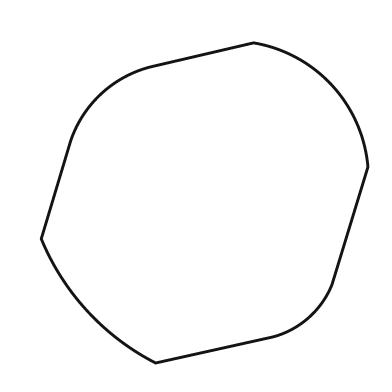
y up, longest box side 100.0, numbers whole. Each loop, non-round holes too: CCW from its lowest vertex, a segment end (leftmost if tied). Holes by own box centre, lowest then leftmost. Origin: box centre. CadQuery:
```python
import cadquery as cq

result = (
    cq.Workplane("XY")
    .moveTo(-15.0, -49.0)
    .lineTo(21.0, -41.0)
    .threePointArc((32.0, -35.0), (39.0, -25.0))
    .lineTo(50.0, 11.0)
    .threePointArc((39.0, 36.0), (15.0, 49.0))
    .lineTo(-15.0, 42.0)
    .threePointArc((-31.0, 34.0), (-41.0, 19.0))
    .lineTo(-50.0, -11.0)
    .threePointArc((-36.0, -33.0), (-15.0, -49.0))
    .close()
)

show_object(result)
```